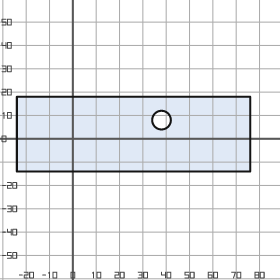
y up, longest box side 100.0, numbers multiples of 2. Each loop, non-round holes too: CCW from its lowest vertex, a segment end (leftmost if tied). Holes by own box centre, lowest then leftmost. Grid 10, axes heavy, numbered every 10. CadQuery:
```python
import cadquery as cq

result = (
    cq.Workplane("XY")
    .moveTo(-24.0, -14.0)
    .lineTo(76.0, -14.0)
    .lineTo(76.0, 18.0)
    .lineTo(-24.0, 18.0)
    .close()
    .moveTo(38.0, 8.0)
    .circle(4.0)
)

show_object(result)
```